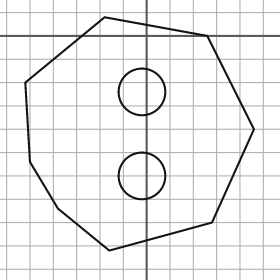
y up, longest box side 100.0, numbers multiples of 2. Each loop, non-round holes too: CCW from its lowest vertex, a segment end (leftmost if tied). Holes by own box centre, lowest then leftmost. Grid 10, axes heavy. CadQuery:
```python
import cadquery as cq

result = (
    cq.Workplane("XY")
    .moveTo(-16.0, -92.0)
    .lineTo(28.0, -80.0)
    .lineTo(46.0, -40.0)
    .lineTo(26.0, 0.0)
    .lineTo(-18.0, 8.0)
    .lineTo(-52.0, -20.0)
    .lineTo(-50.0, -54.0)
    .lineTo(-38.0, -74.0)
    .close()
    .moveTo(-2.0, -60.0)
    .circle(10.0)
    .moveTo(-2.0, -24.0)
    .circle(10.0)
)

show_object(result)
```